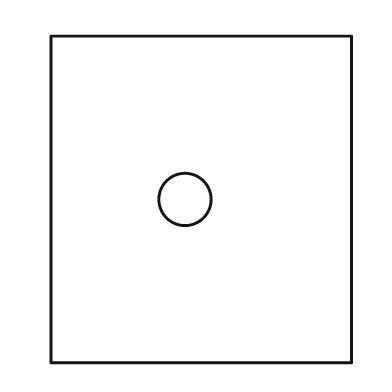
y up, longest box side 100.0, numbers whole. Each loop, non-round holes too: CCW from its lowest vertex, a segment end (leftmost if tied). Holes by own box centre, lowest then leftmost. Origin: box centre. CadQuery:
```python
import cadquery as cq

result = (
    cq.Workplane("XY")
    .moveTo(-46.0, -50.0)
    .lineTo(46.0, -50.0)
    .lineTo(46.0, 50.0)
    .lineTo(-46.0, 50.0)
    .close()
    .moveTo(-5.0, 0.0)
    .circle(8.0)
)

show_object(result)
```